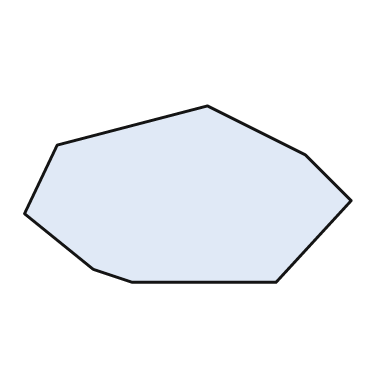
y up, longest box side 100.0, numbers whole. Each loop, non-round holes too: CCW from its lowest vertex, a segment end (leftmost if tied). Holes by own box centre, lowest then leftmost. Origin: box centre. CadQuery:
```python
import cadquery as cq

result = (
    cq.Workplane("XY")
    .moveTo(-17.0, -27.0)
    .lineTo(27.0, -27.0)
    .lineTo(50.0, -2.0)
    .lineTo(36.0, 12.0)
    .lineTo(6.0, 27.0)
    .lineTo(-40.0, 15.0)
    .lineTo(-50.0, -6.0)
    .lineTo(-29.0, -23.0)
    .close()
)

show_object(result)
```